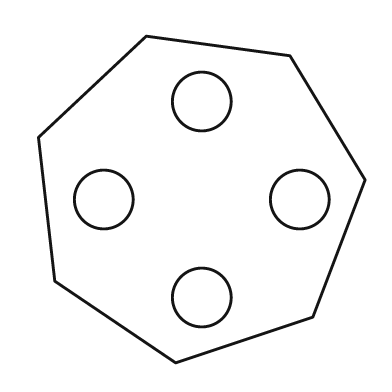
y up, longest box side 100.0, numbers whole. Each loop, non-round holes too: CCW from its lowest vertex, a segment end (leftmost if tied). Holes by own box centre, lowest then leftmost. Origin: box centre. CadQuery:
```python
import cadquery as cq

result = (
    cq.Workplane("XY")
    .moveTo(-8.0, -50.0)
    .lineTo(34.0, -36.0)
    .lineTo(50.0, 6.0)
    .lineTo(27.0, 44.0)
    .lineTo(-17.0, 50.0)
    .lineTo(-50.0, 19.0)
    .lineTo(-45.0, -25.0)
    .close()
    .moveTo(0.0, -30.0)
    .circle(9.0)
    .moveTo(-30.0, 0.0)
    .circle(9.0)
    .moveTo(30.0, 0.0)
    .circle(9.0)
    .moveTo(0.0, 30.0)
    .circle(9.0)
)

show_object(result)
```